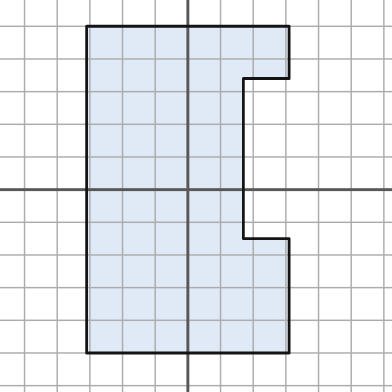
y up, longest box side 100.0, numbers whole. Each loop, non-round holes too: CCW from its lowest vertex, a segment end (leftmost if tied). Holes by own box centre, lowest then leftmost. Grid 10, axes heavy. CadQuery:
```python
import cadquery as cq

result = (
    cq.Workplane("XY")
    .moveTo(-31.0, -50.0)
    .lineTo(31.0, -50.0)
    .lineTo(31.0, -15.0)
    .lineTo(17.0, -15.0)
    .lineTo(17.0, 34.0)
    .lineTo(31.0, 34.0)
    .lineTo(31.0, 50.0)
    .lineTo(-31.0, 50.0)
    .close()
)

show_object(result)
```